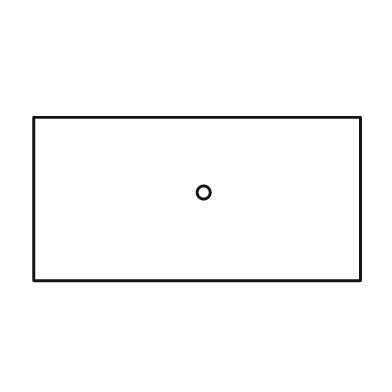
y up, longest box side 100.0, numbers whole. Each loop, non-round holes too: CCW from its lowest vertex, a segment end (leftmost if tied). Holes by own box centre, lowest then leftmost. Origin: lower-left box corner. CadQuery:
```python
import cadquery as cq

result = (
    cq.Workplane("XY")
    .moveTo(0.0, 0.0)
    .lineTo(100.0, 0.0)
    .lineTo(100.0, 50.0)
    .lineTo(0.0, 50.0)
    .close()
    .moveTo(52.0, 27.0)
    .circle(2.0)
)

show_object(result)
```